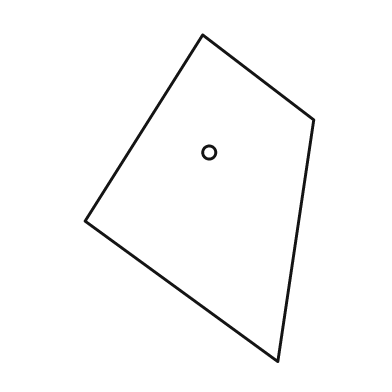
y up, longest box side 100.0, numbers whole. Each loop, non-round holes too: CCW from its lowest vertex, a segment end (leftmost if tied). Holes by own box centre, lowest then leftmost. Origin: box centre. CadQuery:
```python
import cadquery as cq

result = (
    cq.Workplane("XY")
    .moveTo(24.0, -50.0)
    .lineTo(35.0, 24.0)
    .lineTo(1.0, 50.0)
    .lineTo(-35.0, -7.0)
    .close()
    .moveTo(3.0, 14.0)
    .circle(2.0)
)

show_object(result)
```